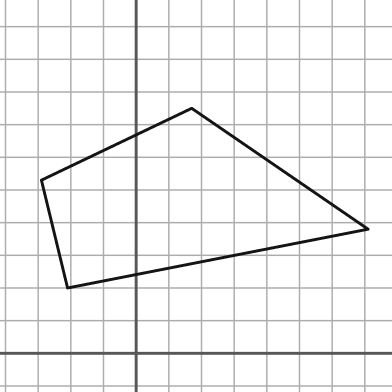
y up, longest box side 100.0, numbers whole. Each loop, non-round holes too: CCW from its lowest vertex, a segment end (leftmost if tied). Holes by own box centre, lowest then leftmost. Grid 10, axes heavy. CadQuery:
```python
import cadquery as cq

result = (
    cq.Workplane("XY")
    .moveTo(-21.0, 20.0)
    .lineTo(71.0, 38.0)
    .lineTo(17.0, 75.0)
    .lineTo(-29.0, 53.0)
    .close()
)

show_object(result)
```